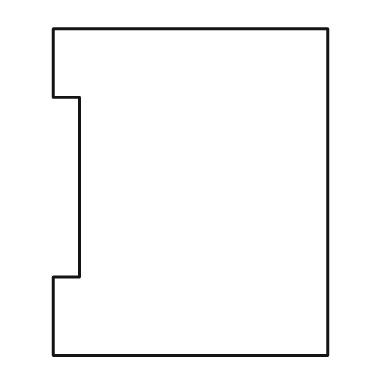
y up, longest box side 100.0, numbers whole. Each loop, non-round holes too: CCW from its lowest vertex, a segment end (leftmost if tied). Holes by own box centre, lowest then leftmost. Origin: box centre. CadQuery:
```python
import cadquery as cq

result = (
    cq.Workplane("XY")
    .moveTo(-42.0, -50.0)
    .lineTo(42.0, -50.0)
    .lineTo(42.0, 50.0)
    .lineTo(-42.0, 50.0)
    .lineTo(-42.0, 29.0)
    .lineTo(-34.0, 29.0)
    .lineTo(-34.0, -26.0)
    .lineTo(-42.0, -26.0)
    .close()
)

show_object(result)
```